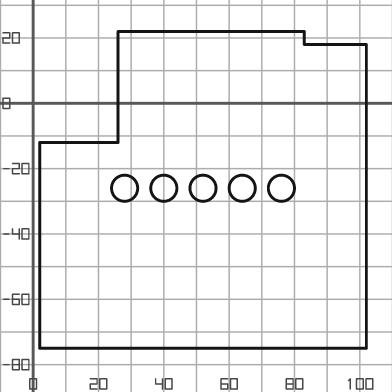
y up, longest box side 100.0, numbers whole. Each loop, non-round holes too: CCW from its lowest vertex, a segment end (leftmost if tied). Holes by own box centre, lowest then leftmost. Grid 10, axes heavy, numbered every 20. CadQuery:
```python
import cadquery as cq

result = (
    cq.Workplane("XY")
    .moveTo(2.0, -75.0)
    .lineTo(102.0, -75.0)
    .lineTo(102.0, 18.0)
    .lineTo(83.0, 18.0)
    .lineTo(83.0, 22.0)
    .lineTo(26.0, 22.0)
    .lineTo(26.0, -12.0)
    .lineTo(2.0, -12.0)
    .close()
    .moveTo(28.0, -26.0)
    .circle(4.0)
    .moveTo(40.0, -26.0)
    .circle(4.0)
    .moveTo(52.0, -26.0)
    .circle(4.0)
    .moveTo(64.0, -26.0)
    .circle(4.0)
    .moveTo(76.0, -26.0)
    .circle(4.0)
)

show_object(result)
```